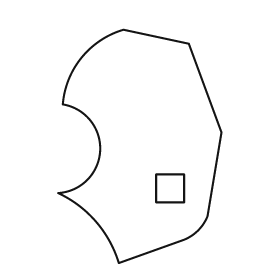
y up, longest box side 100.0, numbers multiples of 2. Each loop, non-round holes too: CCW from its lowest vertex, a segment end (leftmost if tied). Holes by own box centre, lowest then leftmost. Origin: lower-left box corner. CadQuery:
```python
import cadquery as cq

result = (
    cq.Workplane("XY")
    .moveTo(26.0, 0.0)
    .lineTo(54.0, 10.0)
    .threePointArc((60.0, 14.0), (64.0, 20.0))
    .lineTo(70.0, 56.0)
    .lineTo(56.0, 94.0)
    .lineTo(28.0, 100.0)
    .threePointArc((10.0, 88.0), (2.0, 68.0))
    .threePointArc((18.0, 48.0), (0.0, 30.0))
    .threePointArc((16.0, 18.0), (26.0, 0.0))
    .close()
    .moveTo(42.0, 26.0)
    .lineTo(54.0, 26.0)
    .lineTo(54.0, 38.0)
    .lineTo(42.0, 38.0)
    .close()
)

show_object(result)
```